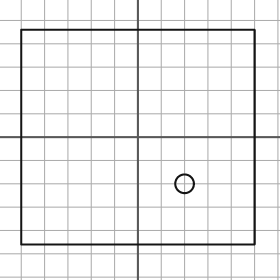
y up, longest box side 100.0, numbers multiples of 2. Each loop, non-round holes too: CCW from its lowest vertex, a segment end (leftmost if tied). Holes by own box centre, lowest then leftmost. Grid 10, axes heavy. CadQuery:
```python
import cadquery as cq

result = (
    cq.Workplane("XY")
    .moveTo(-50.0, -46.0)
    .lineTo(50.0, -46.0)
    .lineTo(50.0, 46.0)
    .lineTo(-50.0, 46.0)
    .close()
    .moveTo(20.0, -20.0)
    .circle(4.0)
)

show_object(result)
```